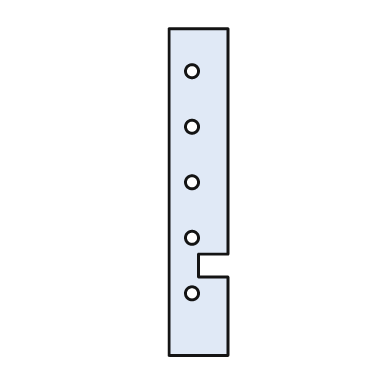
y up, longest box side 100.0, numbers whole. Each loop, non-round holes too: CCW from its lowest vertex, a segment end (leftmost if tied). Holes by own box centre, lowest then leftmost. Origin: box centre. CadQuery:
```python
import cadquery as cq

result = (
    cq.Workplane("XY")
    .moveTo(-9.0, -50.0)
    .lineTo(9.0, -50.0)
    .lineTo(9.0, -26.0)
    .lineTo(0.0, -26.0)
    .lineTo(0.0, -19.0)
    .lineTo(9.0, -19.0)
    .lineTo(9.0, 50.0)
    .lineTo(-9.0, 50.0)
    .close()
    .moveTo(-2.0, -31.0)
    .circle(2.0)
    .moveTo(-2.0, -14.0)
    .circle(2.0)
    .moveTo(-2.0, 3.0)
    .circle(2.0)
    .moveTo(-2.0, 20.0)
    .circle(2.0)
    .moveTo(-2.0, 37.0)
    .circle(2.0)
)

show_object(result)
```